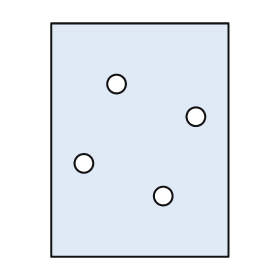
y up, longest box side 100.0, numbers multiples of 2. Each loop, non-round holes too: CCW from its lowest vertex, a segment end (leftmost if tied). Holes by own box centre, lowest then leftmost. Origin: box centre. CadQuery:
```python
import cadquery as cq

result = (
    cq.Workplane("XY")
    .moveTo(-38.0, -50.0)
    .lineTo(38.0, -50.0)
    .lineTo(38.0, 50.0)
    .lineTo(-38.0, 50.0)
    .close()
    .moveTo(10.0, -24.0)
    .circle(4.0)
    .moveTo(-24.0, -10.0)
    .circle(4.0)
    .moveTo(24.0, 10.0)
    .circle(4.0)
    .moveTo(-10.0, 24.0)
    .circle(4.0)
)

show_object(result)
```